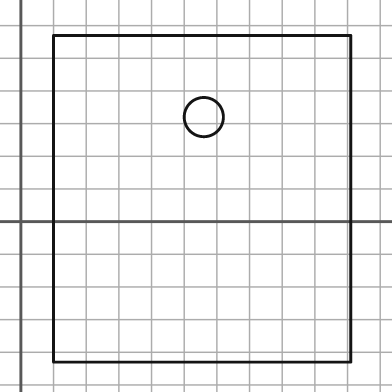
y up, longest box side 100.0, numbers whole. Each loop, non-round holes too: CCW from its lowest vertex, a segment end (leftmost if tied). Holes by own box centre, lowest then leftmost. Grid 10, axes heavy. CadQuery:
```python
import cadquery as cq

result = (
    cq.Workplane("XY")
    .moveTo(10.0, -43.0)
    .lineTo(101.0, -43.0)
    .lineTo(101.0, 57.0)
    .lineTo(10.0, 57.0)
    .close()
    .moveTo(56.0, 32.0)
    .circle(6.0)
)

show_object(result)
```